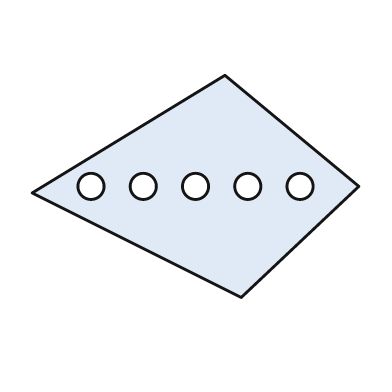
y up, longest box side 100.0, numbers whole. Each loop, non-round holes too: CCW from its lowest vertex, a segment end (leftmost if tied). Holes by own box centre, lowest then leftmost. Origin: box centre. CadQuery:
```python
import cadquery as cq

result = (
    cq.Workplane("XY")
    .moveTo(14.0, -34.0)
    .lineTo(50.0, 0.0)
    .lineTo(9.0, 34.0)
    .lineTo(-50.0, -2.0)
    .close()
    .moveTo(-32.0, 0.0)
    .circle(4.0)
    .moveTo(-16.0, 0.0)
    .circle(4.0)
    .moveTo(0.0, 0.0)
    .circle(4.0)
    .moveTo(16.0, 0.0)
    .circle(4.0)
    .moveTo(32.0, 0.0)
    .circle(4.0)
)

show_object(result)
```